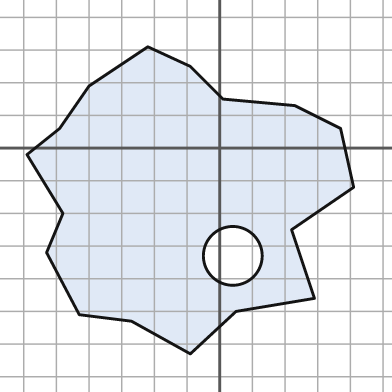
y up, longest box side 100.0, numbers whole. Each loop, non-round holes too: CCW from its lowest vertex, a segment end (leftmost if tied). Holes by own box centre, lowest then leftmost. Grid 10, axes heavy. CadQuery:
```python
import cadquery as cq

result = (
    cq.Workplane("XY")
    .moveTo(-9.0, -63.0)
    .lineTo(5.0, -50.0)
    .lineTo(29.0, -46.0)
    .lineTo(22.0, -25.0)
    .lineTo(41.0, -12.0)
    .lineTo(37.0, 6.0)
    .lineTo(23.0, 13.0)
    .lineTo(1.0, 15.0)
    .lineTo(-9.0, 25.0)
    .lineTo(-22.0, 31.0)
    .lineTo(-40.0, 19.0)
    .lineTo(-49.0, 6.0)
    .lineTo(-59.0, -2.0)
    .lineTo(-48.0, -20.0)
    .lineTo(-53.0, -32.0)
    .lineTo(-43.0, -51.0)
    .lineTo(-27.0, -53.0)
    .close()
    .moveTo(4.0, -33.0)
    .circle(9.0)
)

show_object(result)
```